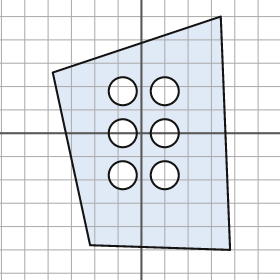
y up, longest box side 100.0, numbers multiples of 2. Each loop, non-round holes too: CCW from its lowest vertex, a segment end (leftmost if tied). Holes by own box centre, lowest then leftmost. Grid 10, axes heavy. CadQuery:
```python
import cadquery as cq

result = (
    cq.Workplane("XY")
    .moveTo(38.0, -50.0)
    .lineTo(34.0, 50.0)
    .lineTo(-38.0, 26.0)
    .lineTo(-22.0, -48.0)
    .close()
    .moveTo(-8.0, -18.0)
    .circle(6.0)
    .moveTo(10.0, -18.0)
    .circle(6.0)
    .moveTo(-8.0, 0.0)
    .circle(6.0)
    .moveTo(10.0, 0.0)
    .circle(6.0)
    .moveTo(-8.0, 18.0)
    .circle(6.0)
    .moveTo(10.0, 18.0)
    .circle(6.0)
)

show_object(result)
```